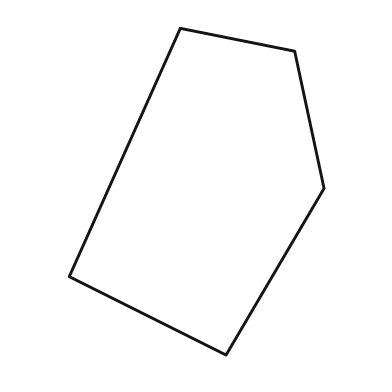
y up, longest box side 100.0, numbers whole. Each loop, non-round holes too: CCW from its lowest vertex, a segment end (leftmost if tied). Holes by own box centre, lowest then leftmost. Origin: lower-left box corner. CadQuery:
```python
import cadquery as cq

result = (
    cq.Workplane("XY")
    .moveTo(48.0, 0.0)
    .lineTo(78.0, 51.0)
    .lineTo(69.0, 93.0)
    .lineTo(34.0, 100.0)
    .lineTo(0.0, 24.0)
    .close()
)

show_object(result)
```